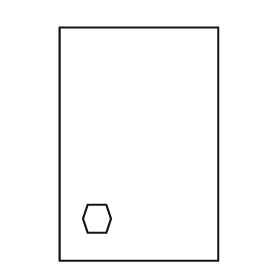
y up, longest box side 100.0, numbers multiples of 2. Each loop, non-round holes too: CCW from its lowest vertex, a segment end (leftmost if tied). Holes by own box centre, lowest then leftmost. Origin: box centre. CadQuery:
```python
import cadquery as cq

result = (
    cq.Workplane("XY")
    .moveTo(-34.0, -50.0)
    .lineTo(34.0, -50.0)
    .lineTo(34.0, 50.0)
    .lineTo(-34.0, 50.0)
    .close()
    .moveTo(-22.0, -38.0)
    .lineTo(-14.0, -38.0)
    .lineTo(-12.0, -32.0)
    .lineTo(-14.0, -26.0)
    .lineTo(-22.0, -26.0)
    .lineTo(-24.0, -32.0)
    .close()
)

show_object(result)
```